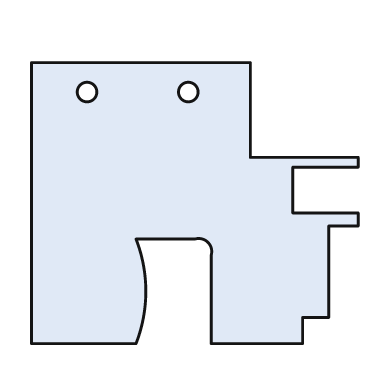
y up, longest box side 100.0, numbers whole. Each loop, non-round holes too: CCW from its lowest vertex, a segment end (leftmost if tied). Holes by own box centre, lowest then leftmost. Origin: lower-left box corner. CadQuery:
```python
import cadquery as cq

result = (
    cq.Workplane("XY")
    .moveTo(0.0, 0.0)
    .lineTo(32.0, 0.0)
    .threePointArc((35.0, 16.0), (32.0, 32.0))
    .lineTo(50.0, 32.0)
    .threePointArc((54.0, 31.0), (55.0, 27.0))
    .lineTo(55.0, 0.0)
    .lineTo(83.0, 0.0)
    .lineTo(83.0, 8.0)
    .lineTo(91.0, 8.0)
    .lineTo(91.0, 36.0)
    .lineTo(100.0, 36.0)
    .lineTo(100.0, 40.0)
    .lineTo(80.0, 40.0)
    .lineTo(80.0, 54.0)
    .lineTo(100.0, 54.0)
    .lineTo(100.0, 57.0)
    .lineTo(67.0, 57.0)
    .lineTo(67.0, 86.0)
    .lineTo(0.0, 86.0)
    .close()
    .moveTo(17.0, 77.0)
    .circle(3.0)
    .moveTo(48.0, 77.0)
    .circle(3.0)
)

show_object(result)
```